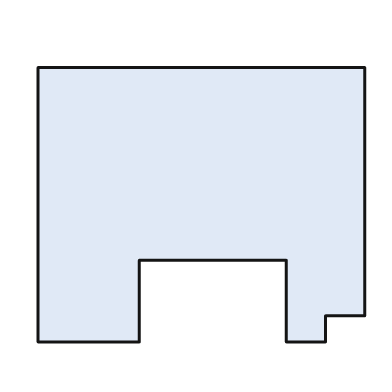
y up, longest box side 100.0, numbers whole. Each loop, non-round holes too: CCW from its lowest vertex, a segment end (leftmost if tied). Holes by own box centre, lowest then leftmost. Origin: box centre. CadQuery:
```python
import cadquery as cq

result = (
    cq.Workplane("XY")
    .moveTo(-50.0, -42.0)
    .lineTo(-19.0, -42.0)
    .lineTo(-19.0, -17.0)
    .lineTo(26.0, -17.0)
    .lineTo(26.0, -42.0)
    .lineTo(38.0, -42.0)
    .lineTo(38.0, -34.0)
    .lineTo(50.0, -34.0)
    .lineTo(50.0, 42.0)
    .lineTo(-50.0, 42.0)
    .close()
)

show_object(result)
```